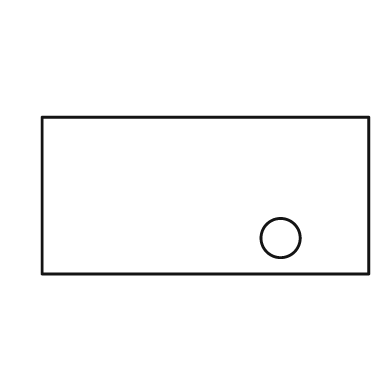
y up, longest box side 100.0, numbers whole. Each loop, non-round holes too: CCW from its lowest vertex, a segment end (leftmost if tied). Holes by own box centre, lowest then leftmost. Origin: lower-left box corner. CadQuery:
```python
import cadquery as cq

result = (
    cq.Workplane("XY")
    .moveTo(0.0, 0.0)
    .lineTo(100.0, 0.0)
    .lineTo(100.0, 48.0)
    .lineTo(0.0, 48.0)
    .close()
    .moveTo(73.0, 11.0)
    .circle(6.0)
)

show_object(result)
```